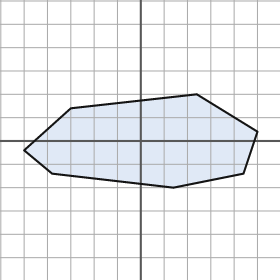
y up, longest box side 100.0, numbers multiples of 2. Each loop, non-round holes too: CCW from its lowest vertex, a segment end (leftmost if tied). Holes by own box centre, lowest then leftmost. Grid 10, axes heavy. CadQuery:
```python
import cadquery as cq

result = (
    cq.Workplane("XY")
    .moveTo(14.0, -20.0)
    .lineTo(44.0, -14.0)
    .lineTo(50.0, 4.0)
    .lineTo(24.0, 20.0)
    .lineTo(-30.0, 14.0)
    .lineTo(-50.0, -4.0)
    .lineTo(-38.0, -14.0)
    .close()
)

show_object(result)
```